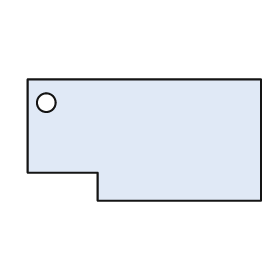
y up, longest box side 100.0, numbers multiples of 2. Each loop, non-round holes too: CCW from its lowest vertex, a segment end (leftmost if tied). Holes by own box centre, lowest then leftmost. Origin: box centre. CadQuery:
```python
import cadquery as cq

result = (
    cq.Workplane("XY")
    .moveTo(-20.0, -26.0)
    .lineTo(50.0, -26.0)
    .lineTo(50.0, 26.0)
    .lineTo(-50.0, 26.0)
    .lineTo(-50.0, -14.0)
    .lineTo(-20.0, -14.0)
    .close()
    .moveTo(-42.0, 16.0)
    .circle(4.0)
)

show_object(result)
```